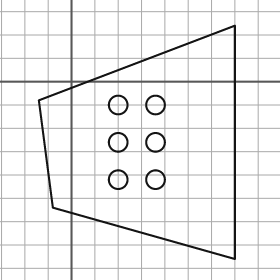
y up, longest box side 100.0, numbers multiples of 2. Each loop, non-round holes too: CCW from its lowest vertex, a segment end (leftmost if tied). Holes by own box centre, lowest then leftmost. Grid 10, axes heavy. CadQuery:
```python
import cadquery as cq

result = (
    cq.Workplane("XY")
    .moveTo(70.0, -76.0)
    .lineTo(70.0, 24.0)
    .lineTo(-14.0, -8.0)
    .lineTo(-8.0, -54.0)
    .close()
    .moveTo(20.0, -42.0)
    .circle(4.0)
    .moveTo(36.0, -42.0)
    .circle(4.0)
    .moveTo(20.0, -26.0)
    .circle(4.0)
    .moveTo(36.0, -26.0)
    .circle(4.0)
    .moveTo(20.0, -10.0)
    .circle(4.0)
    .moveTo(36.0, -10.0)
    .circle(4.0)
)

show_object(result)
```